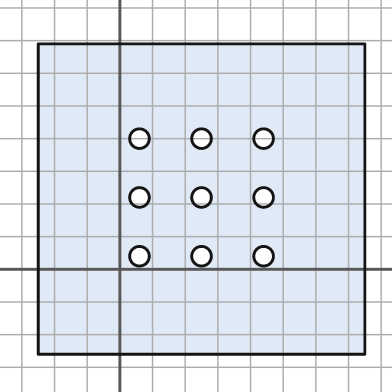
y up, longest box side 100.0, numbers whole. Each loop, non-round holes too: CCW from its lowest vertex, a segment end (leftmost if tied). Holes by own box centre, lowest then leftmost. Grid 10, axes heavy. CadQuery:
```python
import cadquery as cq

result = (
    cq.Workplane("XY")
    .moveTo(-25.0, -26.0)
    .lineTo(75.0, -26.0)
    .lineTo(75.0, 69.0)
    .lineTo(-25.0, 69.0)
    .close()
    .moveTo(6.0, 4.0)
    .circle(3.0)
    .moveTo(25.0, 4.0)
    .circle(3.0)
    .moveTo(44.0, 4.0)
    .circle(3.0)
    .moveTo(6.0, 22.0)
    .circle(3.0)
    .moveTo(25.0, 22.0)
    .circle(3.0)
    .moveTo(44.0, 22.0)
    .circle(3.0)
    .moveTo(6.0, 40.0)
    .circle(3.0)
    .moveTo(25.0, 40.0)
    .circle(3.0)
    .moveTo(44.0, 40.0)
    .circle(3.0)
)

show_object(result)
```